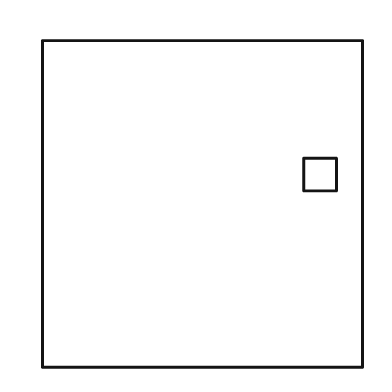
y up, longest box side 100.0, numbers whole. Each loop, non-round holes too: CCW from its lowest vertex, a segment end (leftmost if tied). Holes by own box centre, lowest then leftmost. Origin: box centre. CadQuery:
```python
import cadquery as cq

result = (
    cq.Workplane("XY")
    .moveTo(-49.0, -50.0)
    .lineTo(49.0, -50.0)
    .lineTo(49.0, 50.0)
    .lineTo(-49.0, 50.0)
    .close()
    .moveTo(31.0, 4.0)
    .lineTo(41.0, 4.0)
    .lineTo(41.0, 14.0)
    .lineTo(31.0, 14.0)
    .close()
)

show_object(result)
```